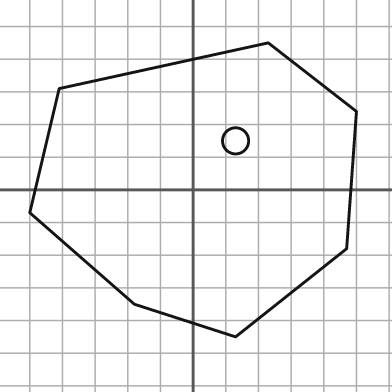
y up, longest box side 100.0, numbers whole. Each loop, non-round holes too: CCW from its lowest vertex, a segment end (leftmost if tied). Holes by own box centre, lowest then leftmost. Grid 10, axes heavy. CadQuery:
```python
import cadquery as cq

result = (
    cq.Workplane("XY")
    .moveTo(13.0, -45.0)
    .lineTo(47.0, -18.0)
    .lineTo(50.0, 24.0)
    .lineTo(23.0, 45.0)
    .lineTo(-41.0, 31.0)
    .lineTo(-50.0, -7.0)
    .lineTo(-18.0, -35.0)
    .close()
    .moveTo(13.0, 15.0)
    .circle(4.0)
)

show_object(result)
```